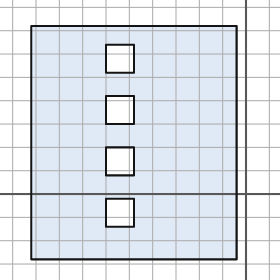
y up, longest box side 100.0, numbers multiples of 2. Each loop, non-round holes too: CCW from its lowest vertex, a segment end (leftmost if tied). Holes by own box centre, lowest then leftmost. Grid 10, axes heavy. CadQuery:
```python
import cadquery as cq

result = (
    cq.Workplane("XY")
    .moveTo(-92.0, -28.0)
    .lineTo(-4.0, -28.0)
    .lineTo(-4.0, 72.0)
    .lineTo(-92.0, 72.0)
    .close()
    .moveTo(-60.0, -14.0)
    .lineTo(-48.0, -14.0)
    .lineTo(-48.0, -2.0)
    .lineTo(-60.0, -2.0)
    .close()
    .moveTo(-60.0, 8.0)
    .lineTo(-48.0, 8.0)
    .lineTo(-48.0, 20.0)
    .lineTo(-60.0, 20.0)
    .close()
    .moveTo(-60.0, 30.0)
    .lineTo(-48.0, 30.0)
    .lineTo(-48.0, 42.0)
    .lineTo(-60.0, 42.0)
    .close()
    .moveTo(-60.0, 52.0)
    .lineTo(-48.0, 52.0)
    .lineTo(-48.0, 64.0)
    .lineTo(-60.0, 64.0)
    .close()
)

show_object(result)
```